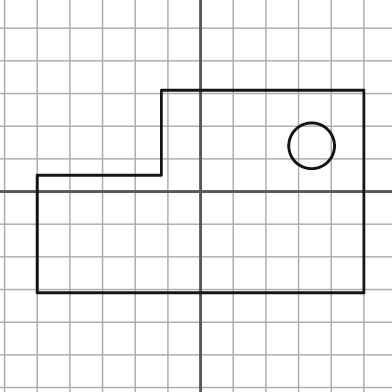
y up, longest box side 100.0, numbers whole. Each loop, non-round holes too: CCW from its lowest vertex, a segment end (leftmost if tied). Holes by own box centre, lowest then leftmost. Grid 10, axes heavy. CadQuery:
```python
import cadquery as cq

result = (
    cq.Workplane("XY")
    .moveTo(-50.0, -31.0)
    .lineTo(50.0, -31.0)
    .lineTo(50.0, 31.0)
    .lineTo(-12.0, 31.0)
    .lineTo(-12.0, 5.0)
    .lineTo(-50.0, 5.0)
    .close()
    .moveTo(34.0, 14.0)
    .circle(7.0)
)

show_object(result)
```